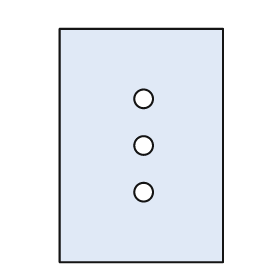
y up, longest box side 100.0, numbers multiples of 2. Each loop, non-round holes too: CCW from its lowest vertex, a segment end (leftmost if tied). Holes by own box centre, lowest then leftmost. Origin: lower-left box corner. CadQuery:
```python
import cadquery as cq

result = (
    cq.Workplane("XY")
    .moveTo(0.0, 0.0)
    .lineTo(70.0, 0.0)
    .lineTo(70.0, 100.0)
    .lineTo(0.0, 100.0)
    .close()
    .moveTo(36.0, 30.0)
    .circle(4.0)
    .moveTo(36.0, 50.0)
    .circle(4.0)
    .moveTo(36.0, 70.0)
    .circle(4.0)
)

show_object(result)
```